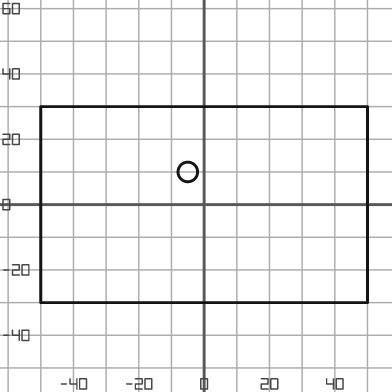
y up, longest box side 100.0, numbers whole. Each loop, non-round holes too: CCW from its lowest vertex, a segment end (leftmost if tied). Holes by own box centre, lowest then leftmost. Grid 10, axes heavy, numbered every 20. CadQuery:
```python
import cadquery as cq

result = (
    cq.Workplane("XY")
    .moveTo(-50.0, -30.0)
    .lineTo(50.0, -30.0)
    .lineTo(50.0, 30.0)
    .lineTo(-50.0, 30.0)
    .close()
    .moveTo(-5.0, 10.0)
    .circle(3.0)
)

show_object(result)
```